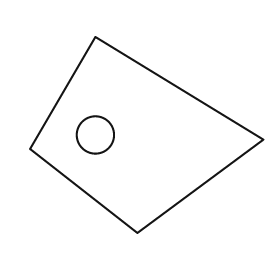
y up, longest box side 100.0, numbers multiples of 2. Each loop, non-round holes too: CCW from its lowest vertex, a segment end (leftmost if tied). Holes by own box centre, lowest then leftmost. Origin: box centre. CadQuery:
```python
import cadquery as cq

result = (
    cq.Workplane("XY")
    .moveTo(-4.0, -42.0)
    .lineTo(50.0, -2.0)
    .lineTo(-22.0, 42.0)
    .lineTo(-50.0, -6.0)
    .close()
    .moveTo(-22.0, 0.0)
    .circle(8.0)
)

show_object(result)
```